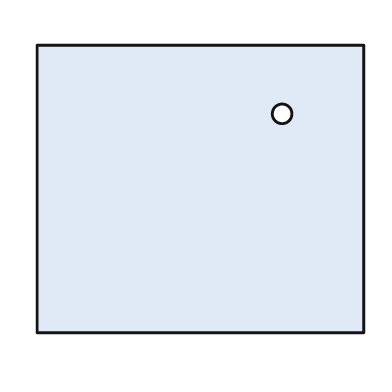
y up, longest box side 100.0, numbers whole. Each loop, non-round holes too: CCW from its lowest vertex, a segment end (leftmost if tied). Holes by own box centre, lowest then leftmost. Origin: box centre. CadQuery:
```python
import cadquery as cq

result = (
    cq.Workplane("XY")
    .moveTo(-50.0, -44.0)
    .lineTo(50.0, -44.0)
    .lineTo(50.0, 44.0)
    .lineTo(-50.0, 44.0)
    .close()
    .moveTo(25.0, 23.0)
    .circle(3.0)
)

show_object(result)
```